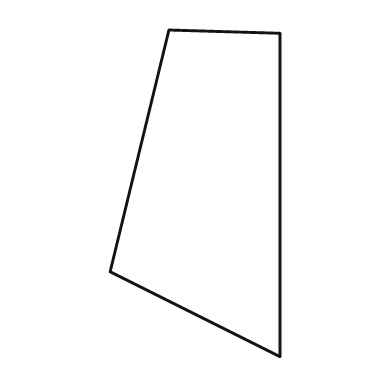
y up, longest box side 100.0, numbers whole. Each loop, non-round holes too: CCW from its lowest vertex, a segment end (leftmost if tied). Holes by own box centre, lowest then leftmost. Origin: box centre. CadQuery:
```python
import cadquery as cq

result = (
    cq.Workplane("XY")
    .moveTo(26.0, -50.0)
    .lineTo(26.0, 49.0)
    .lineTo(-8.0, 50.0)
    .lineTo(-26.0, -24.0)
    .close()
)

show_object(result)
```